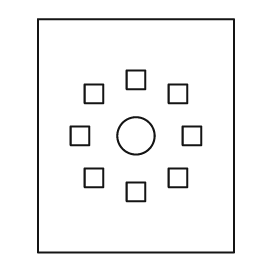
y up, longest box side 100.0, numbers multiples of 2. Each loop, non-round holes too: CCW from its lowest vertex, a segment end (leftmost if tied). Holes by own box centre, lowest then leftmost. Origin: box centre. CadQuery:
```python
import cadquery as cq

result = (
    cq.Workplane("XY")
    .moveTo(-42.0, -50.0)
    .lineTo(42.0, -50.0)
    .lineTo(42.0, 50.0)
    .lineTo(-42.0, 50.0)
    .close()
    .moveTo(-4.0, -28.0)
    .lineTo(4.0, -28.0)
    .lineTo(4.0, -20.0)
    .lineTo(-4.0, -20.0)
    .close()
    .moveTo(-22.0, -22.0)
    .lineTo(-14.0, -22.0)
    .lineTo(-14.0, -14.0)
    .lineTo(-22.0, -14.0)
    .close()
    .moveTo(14.0, -22.0)
    .lineTo(22.0, -22.0)
    .lineTo(22.0, -14.0)
    .lineTo(14.0, -14.0)
    .close()
    .moveTo(-28.0, -4.0)
    .lineTo(-20.0, -4.0)
    .lineTo(-20.0, 4.0)
    .lineTo(-28.0, 4.0)
    .close()
    .moveTo(0.0, 0.0)
    .circle(8.0)
    .moveTo(20.0, -4.0)
    .lineTo(28.0, -4.0)
    .lineTo(28.0, 4.0)
    .lineTo(20.0, 4.0)
    .close()
    .moveTo(-22.0, 14.0)
    .lineTo(-14.0, 14.0)
    .lineTo(-14.0, 22.0)
    .lineTo(-22.0, 22.0)
    .close()
    .moveTo(14.0, 14.0)
    .lineTo(22.0, 14.0)
    .lineTo(22.0, 22.0)
    .lineTo(14.0, 22.0)
    .close()
    .moveTo(-4.0, 20.0)
    .lineTo(4.0, 20.0)
    .lineTo(4.0, 28.0)
    .lineTo(-4.0, 28.0)
    .close()
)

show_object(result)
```